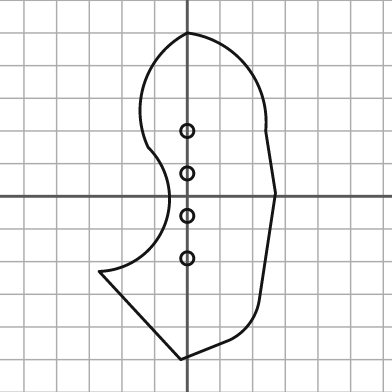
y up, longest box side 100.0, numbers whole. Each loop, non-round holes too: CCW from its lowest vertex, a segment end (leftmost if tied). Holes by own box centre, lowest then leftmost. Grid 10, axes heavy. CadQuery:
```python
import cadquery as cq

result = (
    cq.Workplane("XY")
    .moveTo(-2.0, -50.0)
    .lineTo(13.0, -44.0)
    .threePointArc((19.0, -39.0), (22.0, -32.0))
    .lineTo(27.0, 1.0)
    .lineTo(24.0, 20.0)
    .threePointArc((18.0, 40.0), (0.0, 50.0))
    .threePointArc((-13.0, 35.0), (-12.0, 15.0))
    .threePointArc((-7.0, -9.0), (-27.0, -23.0))
    .close()
    .moveTo(0.0, -19.0)
    .circle(2.0)
    .moveTo(0.0, -6.0)
    .circle(2.0)
    .moveTo(0.0, 7.0)
    .circle(2.0)
    .moveTo(0.0, 20.0)
    .circle(2.0)
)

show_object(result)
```